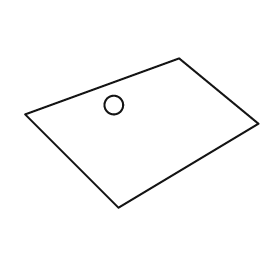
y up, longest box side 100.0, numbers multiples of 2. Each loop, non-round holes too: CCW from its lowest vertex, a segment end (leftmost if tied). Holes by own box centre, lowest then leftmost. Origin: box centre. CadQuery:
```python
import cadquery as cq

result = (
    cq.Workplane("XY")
    .moveTo(-10.0, -32.0)
    .lineTo(50.0, 4.0)
    .lineTo(16.0, 32.0)
    .lineTo(-50.0, 8.0)
    .close()
    .moveTo(-12.0, 12.0)
    .circle(4.0)
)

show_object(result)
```